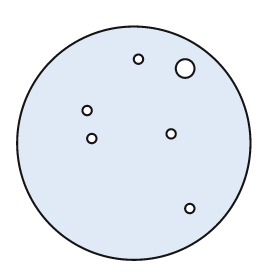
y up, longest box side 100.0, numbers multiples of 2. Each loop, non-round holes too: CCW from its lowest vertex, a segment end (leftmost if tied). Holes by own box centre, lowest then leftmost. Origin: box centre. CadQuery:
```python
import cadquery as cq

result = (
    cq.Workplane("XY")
    .moveTo(0.0, 0.0)
    .circle(50.0)
    .moveTo(24.0, -28.0)
    .circle(2.0)
    .moveTo(-18.0, 2.0)
    .circle(2.0)
    .moveTo(16.0, 4.0)
    .circle(2.0)
    .moveTo(-20.0, 14.0)
    .circle(2.0)
    .moveTo(22.0, 32.0)
    .circle(4.0)
    .moveTo(2.0, 36.0)
    .circle(2.0)
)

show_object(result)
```